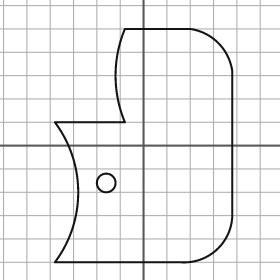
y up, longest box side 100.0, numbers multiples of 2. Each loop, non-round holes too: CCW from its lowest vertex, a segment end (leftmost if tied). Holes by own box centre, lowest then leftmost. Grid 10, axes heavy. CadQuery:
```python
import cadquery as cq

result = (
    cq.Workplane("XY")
    .moveTo(-38.0, -50.0)
    .lineTo(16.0, -50.0)
    .threePointArc((32.0, -44.0), (38.0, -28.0))
    .lineTo(38.0, 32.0)
    .threePointArc((32.0, 44.0), (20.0, 50.0))
    .lineTo(-8.0, 50.0)
    .threePointArc((-12.0, 30.0), (-8.0, 10.0))
    .lineTo(-38.0, 10.0)
    .threePointArc((-28.0, -20.0), (-38.0, -50.0))
    .close()
    .moveTo(-16.0, -16.0)
    .circle(4.0)
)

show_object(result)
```